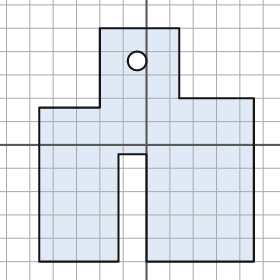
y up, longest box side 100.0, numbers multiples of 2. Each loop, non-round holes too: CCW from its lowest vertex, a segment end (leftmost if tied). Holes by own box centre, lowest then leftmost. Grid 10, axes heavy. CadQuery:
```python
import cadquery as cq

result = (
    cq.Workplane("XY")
    .moveTo(-46.0, -50.0)
    .lineTo(-12.0, -50.0)
    .lineTo(-12.0, -4.0)
    .lineTo(0.0, -4.0)
    .lineTo(0.0, -50.0)
    .lineTo(46.0, -50.0)
    .lineTo(46.0, 20.0)
    .lineTo(14.0, 20.0)
    .lineTo(14.0, 50.0)
    .lineTo(-20.0, 50.0)
    .lineTo(-20.0, 16.0)
    .lineTo(-46.0, 16.0)
    .close()
    .moveTo(-4.0, 36.0)
    .circle(4.0)
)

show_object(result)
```